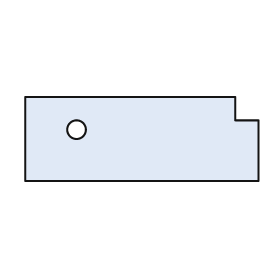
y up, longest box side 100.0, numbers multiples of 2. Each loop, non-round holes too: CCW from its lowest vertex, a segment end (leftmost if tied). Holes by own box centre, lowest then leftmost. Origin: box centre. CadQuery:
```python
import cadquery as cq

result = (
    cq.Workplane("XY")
    .moveTo(-50.0, -18.0)
    .lineTo(50.0, -18.0)
    .lineTo(50.0, 8.0)
    .lineTo(40.0, 8.0)
    .lineTo(40.0, 18.0)
    .lineTo(-50.0, 18.0)
    .close()
    .moveTo(-28.0, 4.0)
    .circle(4.0)
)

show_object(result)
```